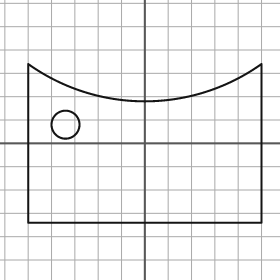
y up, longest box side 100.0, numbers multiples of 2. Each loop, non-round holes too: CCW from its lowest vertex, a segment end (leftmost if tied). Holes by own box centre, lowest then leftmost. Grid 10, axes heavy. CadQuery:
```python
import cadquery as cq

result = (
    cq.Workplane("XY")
    .moveTo(-50.0, -34.0)
    .lineTo(50.0, -34.0)
    .lineTo(50.0, 34.0)
    .threePointArc((0.0, 18.0), (-50.0, 34.0))
    .close()
    .moveTo(-34.0, 8.0)
    .circle(6.0)
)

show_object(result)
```